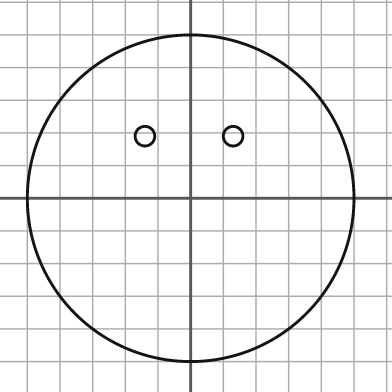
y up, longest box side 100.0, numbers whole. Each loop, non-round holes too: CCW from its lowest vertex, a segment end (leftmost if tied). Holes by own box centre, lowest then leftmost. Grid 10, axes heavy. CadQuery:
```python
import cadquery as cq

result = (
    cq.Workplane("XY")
    .moveTo(0.0, 0.0)
    .circle(50.0)
    .moveTo(-14.0, 19.0)
    .circle(3.0)
    .moveTo(13.0, 19.0)
    .circle(3.0)
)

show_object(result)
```